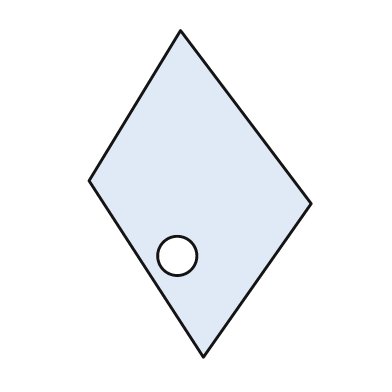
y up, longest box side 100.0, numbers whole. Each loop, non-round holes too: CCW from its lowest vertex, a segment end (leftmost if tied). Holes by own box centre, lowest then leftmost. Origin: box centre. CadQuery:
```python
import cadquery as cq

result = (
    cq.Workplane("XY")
    .moveTo(1.0, -50.0)
    .lineTo(34.0, -3.0)
    .lineTo(-6.0, 50.0)
    .lineTo(-34.0, 4.0)
    .close()
    .moveTo(-7.0, -19.0)
    .circle(6.0)
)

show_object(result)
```